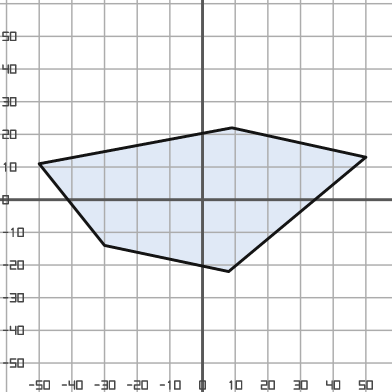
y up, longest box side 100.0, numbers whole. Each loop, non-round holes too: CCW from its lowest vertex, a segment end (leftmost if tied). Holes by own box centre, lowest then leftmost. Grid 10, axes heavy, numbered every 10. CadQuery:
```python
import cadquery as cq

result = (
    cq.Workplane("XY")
    .moveTo(8.0, -22.0)
    .lineTo(50.0, 13.0)
    .lineTo(9.0, 22.0)
    .lineTo(-50.0, 11.0)
    .lineTo(-30.0, -14.0)
    .close()
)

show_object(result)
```